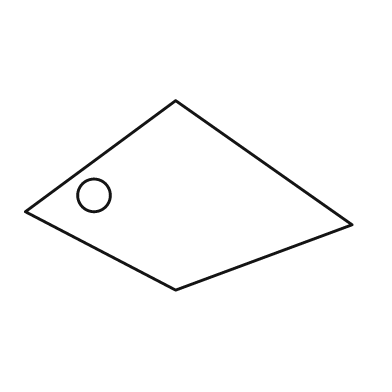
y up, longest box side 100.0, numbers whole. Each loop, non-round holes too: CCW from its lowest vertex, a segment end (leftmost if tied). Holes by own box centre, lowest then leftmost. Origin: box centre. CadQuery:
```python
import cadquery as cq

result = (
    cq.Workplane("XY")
    .moveTo(-4.0, -29.0)
    .lineTo(50.0, -9.0)
    .lineTo(-4.0, 29.0)
    .lineTo(-50.0, -5.0)
    .close()
    .moveTo(-29.0, 0.0)
    .circle(5.0)
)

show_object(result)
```